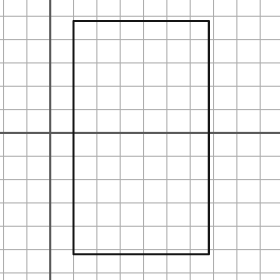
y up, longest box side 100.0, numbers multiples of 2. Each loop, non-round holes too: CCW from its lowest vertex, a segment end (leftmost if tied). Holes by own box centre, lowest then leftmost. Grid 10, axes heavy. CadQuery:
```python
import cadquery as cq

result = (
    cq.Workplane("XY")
    .moveTo(10.0, -52.0)
    .lineTo(68.0, -52.0)
    .lineTo(68.0, 48.0)
    .lineTo(10.0, 48.0)
    .close()
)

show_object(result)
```